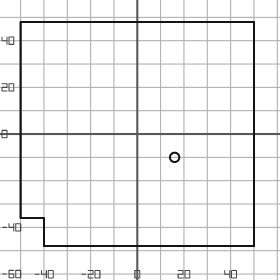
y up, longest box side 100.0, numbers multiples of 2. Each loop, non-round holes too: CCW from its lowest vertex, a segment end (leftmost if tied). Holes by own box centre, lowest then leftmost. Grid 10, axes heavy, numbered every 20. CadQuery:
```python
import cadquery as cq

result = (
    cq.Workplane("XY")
    .moveTo(-40.0, -48.0)
    .lineTo(50.0, -48.0)
    .lineTo(50.0, 48.0)
    .lineTo(-50.0, 48.0)
    .lineTo(-50.0, -36.0)
    .lineTo(-40.0, -36.0)
    .close()
    .moveTo(16.0, -10.0)
    .circle(2.0)
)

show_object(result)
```